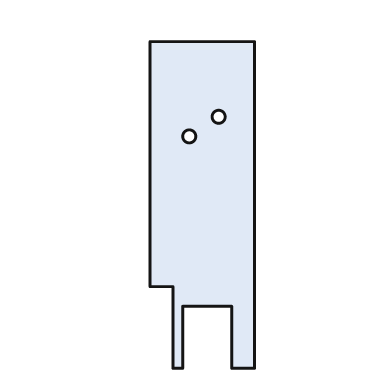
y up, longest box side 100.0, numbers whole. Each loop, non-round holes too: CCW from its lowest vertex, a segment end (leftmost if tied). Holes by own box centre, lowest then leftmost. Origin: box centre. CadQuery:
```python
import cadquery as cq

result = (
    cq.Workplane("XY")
    .moveTo(-9.0, -50.0)
    .lineTo(-6.0, -50.0)
    .lineTo(-6.0, -31.0)
    .lineTo(9.0, -31.0)
    .lineTo(9.0, -50.0)
    .lineTo(16.0, -50.0)
    .lineTo(16.0, 50.0)
    .lineTo(-16.0, 50.0)
    .lineTo(-16.0, -25.0)
    .lineTo(-9.0, -25.0)
    .close()
    .moveTo(-4.0, 21.0)
    .circle(2.0)
    .moveTo(5.0, 27.0)
    .circle(2.0)
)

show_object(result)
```